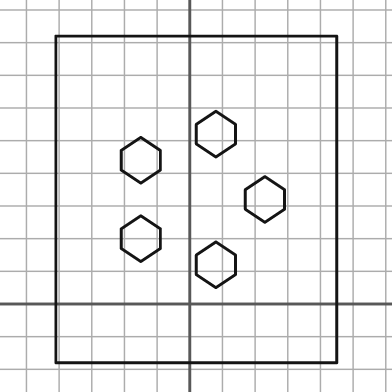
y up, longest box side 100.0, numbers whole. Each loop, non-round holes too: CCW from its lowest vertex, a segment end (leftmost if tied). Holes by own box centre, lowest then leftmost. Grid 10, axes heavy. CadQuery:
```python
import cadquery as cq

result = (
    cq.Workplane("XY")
    .moveTo(-41.0, -18.0)
    .lineTo(45.0, -18.0)
    .lineTo(45.0, 82.0)
    .lineTo(-41.0, 82.0)
    .close()
    .moveTo(8.0, 5.0)
    .lineTo(14.0, 9.0)
    .lineTo(14.0, 15.0)
    .lineTo(8.0, 19.0)
    .lineTo(2.0, 15.0)
    .lineTo(2.0, 9.0)
    .close()
    .moveTo(-15.0, 13.0)
    .lineTo(-9.0, 17.0)
    .lineTo(-9.0, 23.0)
    .lineTo(-15.0, 27.0)
    .lineTo(-21.0, 23.0)
    .lineTo(-21.0, 17.0)
    .close()
    .moveTo(23.0, 25.0)
    .lineTo(29.0, 29.0)
    .lineTo(29.0, 35.0)
    .lineTo(23.0, 39.0)
    .lineTo(17.0, 35.0)
    .lineTo(17.0, 29.0)
    .close()
    .moveTo(-15.0, 37.0)
    .lineTo(-9.0, 41.0)
    .lineTo(-9.0, 47.0)
    .lineTo(-15.0, 51.0)
    .lineTo(-21.0, 47.0)
    .lineTo(-21.0, 41.0)
    .close()
    .moveTo(8.0, 45.0)
    .lineTo(14.0, 49.0)
    .lineTo(14.0, 55.0)
    .lineTo(8.0, 59.0)
    .lineTo(2.0, 55.0)
    .lineTo(2.0, 49.0)
    .close()
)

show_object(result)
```